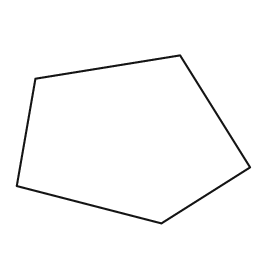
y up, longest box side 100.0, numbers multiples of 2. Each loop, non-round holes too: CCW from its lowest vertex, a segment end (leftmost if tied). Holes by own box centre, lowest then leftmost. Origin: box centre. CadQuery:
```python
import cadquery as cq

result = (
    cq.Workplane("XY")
    .moveTo(12.0, -36.0)
    .lineTo(50.0, -12.0)
    .lineTo(20.0, 36.0)
    .lineTo(-42.0, 26.0)
    .lineTo(-50.0, -20.0)
    .close()
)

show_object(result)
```